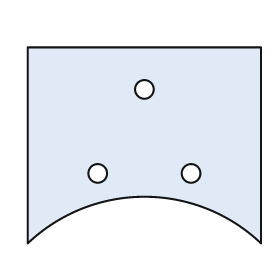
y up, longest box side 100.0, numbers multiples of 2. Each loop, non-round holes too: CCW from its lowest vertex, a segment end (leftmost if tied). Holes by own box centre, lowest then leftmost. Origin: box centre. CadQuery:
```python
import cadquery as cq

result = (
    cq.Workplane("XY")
    .moveTo(-50.0, -42.0)
    .threePointArc((0.0, -22.0), (50.0, -42.0))
    .lineTo(50.0, 42.0)
    .lineTo(-50.0, 42.0)
    .close()
    .moveTo(-20.0, -12.0)
    .circle(4.0)
    .moveTo(20.0, -12.0)
    .circle(4.0)
    .moveTo(0.0, 24.0)
    .circle(4.0)
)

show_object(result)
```